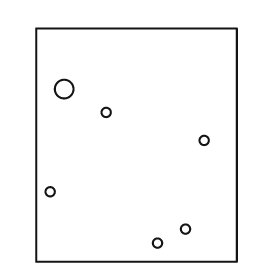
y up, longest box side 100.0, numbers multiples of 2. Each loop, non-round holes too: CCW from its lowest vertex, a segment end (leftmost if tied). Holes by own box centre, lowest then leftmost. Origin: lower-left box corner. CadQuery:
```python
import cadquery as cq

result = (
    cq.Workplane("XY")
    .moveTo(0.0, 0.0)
    .lineTo(86.0, 0.0)
    .lineTo(86.0, 100.0)
    .lineTo(0.0, 100.0)
    .close()
    .moveTo(52.0, 8.0)
    .circle(2.0)
    .moveTo(64.0, 14.0)
    .circle(2.0)
    .moveTo(6.0, 30.0)
    .circle(2.0)
    .moveTo(72.0, 52.0)
    .circle(2.0)
    .moveTo(30.0, 64.0)
    .circle(2.0)
    .moveTo(12.0, 74.0)
    .circle(4.0)
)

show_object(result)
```